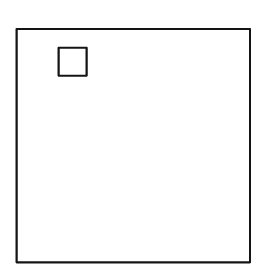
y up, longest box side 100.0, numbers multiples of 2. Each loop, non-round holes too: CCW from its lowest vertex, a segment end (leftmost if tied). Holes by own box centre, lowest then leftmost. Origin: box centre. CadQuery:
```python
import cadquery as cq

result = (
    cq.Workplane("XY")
    .moveTo(-50.0, -50.0)
    .lineTo(50.0, -50.0)
    .lineTo(50.0, 50.0)
    .lineTo(-50.0, 50.0)
    .close()
    .moveTo(-32.0, 30.0)
    .lineTo(-20.0, 30.0)
    .lineTo(-20.0, 42.0)
    .lineTo(-32.0, 42.0)
    .close()
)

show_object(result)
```